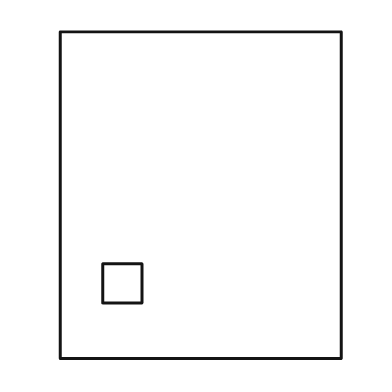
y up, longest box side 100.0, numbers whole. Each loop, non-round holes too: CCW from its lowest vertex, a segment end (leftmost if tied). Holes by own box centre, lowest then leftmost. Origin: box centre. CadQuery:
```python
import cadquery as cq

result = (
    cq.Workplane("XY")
    .moveTo(-43.0, -50.0)
    .lineTo(43.0, -50.0)
    .lineTo(43.0, 50.0)
    .lineTo(-43.0, 50.0)
    .close()
    .moveTo(-30.0, -33.0)
    .lineTo(-18.0, -33.0)
    .lineTo(-18.0, -21.0)
    .lineTo(-30.0, -21.0)
    .close()
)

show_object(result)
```